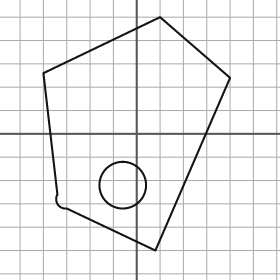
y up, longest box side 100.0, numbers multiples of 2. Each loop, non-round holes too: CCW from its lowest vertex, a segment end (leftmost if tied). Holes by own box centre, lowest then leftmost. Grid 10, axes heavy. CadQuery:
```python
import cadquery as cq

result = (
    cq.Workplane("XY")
    .moveTo(8.0, -50.0)
    .lineTo(40.0, 24.0)
    .lineTo(10.0, 50.0)
    .lineTo(-40.0, 26.0)
    .lineTo(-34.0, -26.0)
    .threePointArc((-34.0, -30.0), (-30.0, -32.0))
    .close()
    .moveTo(-6.0, -22.0)
    .circle(10.0)
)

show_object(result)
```